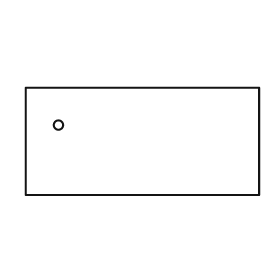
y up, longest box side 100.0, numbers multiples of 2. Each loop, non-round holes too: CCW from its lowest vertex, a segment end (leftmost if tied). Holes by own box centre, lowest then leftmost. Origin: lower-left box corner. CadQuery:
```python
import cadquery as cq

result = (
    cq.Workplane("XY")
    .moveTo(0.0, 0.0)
    .lineTo(100.0, 0.0)
    .lineTo(100.0, 46.0)
    .lineTo(0.0, 46.0)
    .close()
    .moveTo(14.0, 30.0)
    .circle(2.0)
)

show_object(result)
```